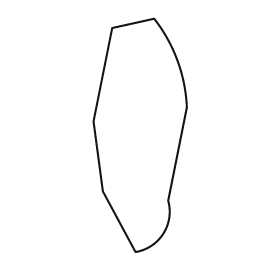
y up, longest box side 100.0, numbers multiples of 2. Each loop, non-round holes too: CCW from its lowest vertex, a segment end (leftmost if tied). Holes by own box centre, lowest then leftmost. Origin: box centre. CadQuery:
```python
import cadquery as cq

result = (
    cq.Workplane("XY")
    .moveTo(-2.0, -50.0)
    .threePointArc((10.0, -42.0), (12.0, -28.0))
    .lineTo(20.0, 12.0)
    .threePointArc((16.0, 32.0), (6.0, 50.0))
    .lineTo(-12.0, 46.0)
    .lineTo(-20.0, 6.0)
    .lineTo(-16.0, -24.0)
    .close()
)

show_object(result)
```